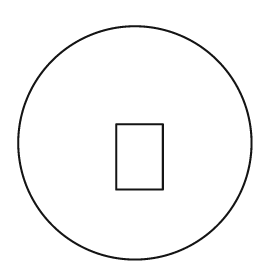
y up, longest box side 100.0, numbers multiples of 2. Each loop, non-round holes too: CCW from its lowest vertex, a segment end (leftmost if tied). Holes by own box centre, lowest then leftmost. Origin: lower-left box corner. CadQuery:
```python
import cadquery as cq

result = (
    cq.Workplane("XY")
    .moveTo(50.0, 50.0)
    .circle(50.0)
    .moveTo(42.0, 30.0)
    .lineTo(62.0, 30.0)
    .lineTo(62.0, 58.0)
    .lineTo(42.0, 58.0)
    .close()
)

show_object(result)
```